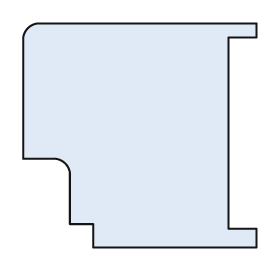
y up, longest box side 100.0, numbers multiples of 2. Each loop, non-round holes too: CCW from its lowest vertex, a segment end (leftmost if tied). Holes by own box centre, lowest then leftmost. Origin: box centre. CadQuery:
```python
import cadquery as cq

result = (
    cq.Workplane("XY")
    .moveTo(-20.0, -48.0)
    .lineTo(50.0, -48.0)
    .lineTo(50.0, -40.0)
    .lineTo(38.0, -40.0)
    .lineTo(38.0, 42.0)
    .lineTo(50.0, 42.0)
    .lineTo(50.0, 48.0)
    .lineTo(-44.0, 48.0)
    .threePointArc((-48.0, 46.0), (-50.0, 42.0))
    .lineTo(-50.0, -10.0)
    .lineTo(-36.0, -10.0)
    .threePointArc((-32.0, -12.0), (-30.0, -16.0))
    .lineTo(-30.0, -38.0)
    .lineTo(-20.0, -38.0)
    .close()
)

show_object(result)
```